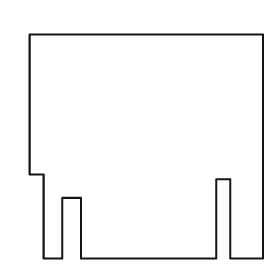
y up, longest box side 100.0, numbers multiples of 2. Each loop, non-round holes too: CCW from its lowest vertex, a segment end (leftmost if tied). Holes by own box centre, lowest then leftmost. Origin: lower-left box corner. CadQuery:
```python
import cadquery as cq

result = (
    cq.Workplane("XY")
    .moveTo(6.0, 0.0)
    .lineTo(14.0, 0.0)
    .lineTo(14.0, 26.0)
    .lineTo(22.0, 26.0)
    .lineTo(22.0, 0.0)
    .lineTo(80.0, 0.0)
    .lineTo(80.0, 34.0)
    .lineTo(86.0, 34.0)
    .lineTo(86.0, 0.0)
    .lineTo(100.0, 0.0)
    .lineTo(100.0, 96.0)
    .lineTo(0.0, 96.0)
    .lineTo(0.0, 36.0)
    .lineTo(6.0, 36.0)
    .close()
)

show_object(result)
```